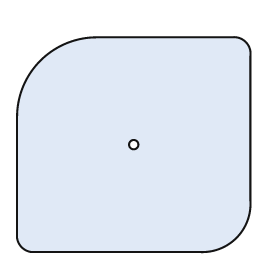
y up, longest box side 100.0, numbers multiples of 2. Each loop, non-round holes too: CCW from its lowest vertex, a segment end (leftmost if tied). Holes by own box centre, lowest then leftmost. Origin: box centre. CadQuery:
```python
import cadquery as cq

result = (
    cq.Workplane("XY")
    .moveTo(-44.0, -46.0)
    .lineTo(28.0, -46.0)
    .threePointArc((44.0, -40.0), (50.0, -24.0))
    .lineTo(50.0, 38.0)
    .threePointArc((48.0, 44.0), (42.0, 46.0))
    .lineTo(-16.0, 46.0)
    .threePointArc((-40.0, 36.0), (-50.0, 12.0))
    .lineTo(-50.0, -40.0)
    .threePointArc((-48.0, -44.0), (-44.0, -46.0))
    .close()
    .moveTo(0.0, 0.0)
    .circle(2.0)
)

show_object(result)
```